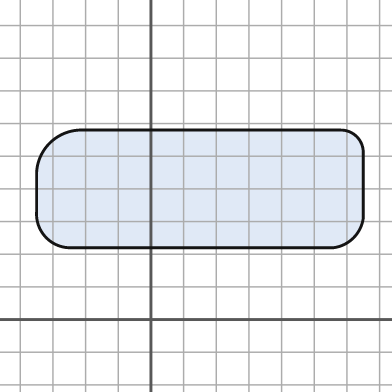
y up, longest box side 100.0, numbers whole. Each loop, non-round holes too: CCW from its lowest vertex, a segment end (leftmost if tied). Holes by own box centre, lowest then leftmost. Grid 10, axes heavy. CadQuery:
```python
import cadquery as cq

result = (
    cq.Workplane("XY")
    .moveTo(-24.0, 22.0)
    .lineTo(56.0, 22.0)
    .threePointArc((62.0, 25.0), (65.0, 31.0))
    .lineTo(65.0, 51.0)
    .threePointArc((63.0, 56.0), (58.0, 58.0))
    .lineTo(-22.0, 58.0)
    .threePointArc((-31.0, 54.0), (-35.0, 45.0))
    .lineTo(-35.0, 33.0)
    .threePointArc((-32.0, 25.0), (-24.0, 22.0))
    .close()
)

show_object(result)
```